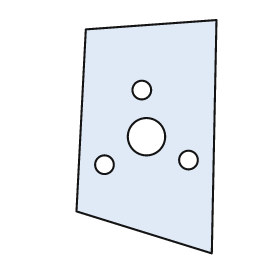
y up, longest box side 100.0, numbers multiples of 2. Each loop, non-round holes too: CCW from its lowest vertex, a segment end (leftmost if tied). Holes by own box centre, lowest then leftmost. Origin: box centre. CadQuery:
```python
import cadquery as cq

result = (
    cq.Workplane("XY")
    .moveTo(28.0, -50.0)
    .lineTo(30.0, 50.0)
    .lineTo(-26.0, 46.0)
    .lineTo(-30.0, -32.0)
    .close()
    .moveTo(-18.0, -12.0)
    .circle(4.0)
    .moveTo(18.0, -10.0)
    .circle(4.0)
    .moveTo(0.0, 0.0)
    .circle(8.0)
    .moveTo(-2.0, 20.0)
    .circle(4.0)
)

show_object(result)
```